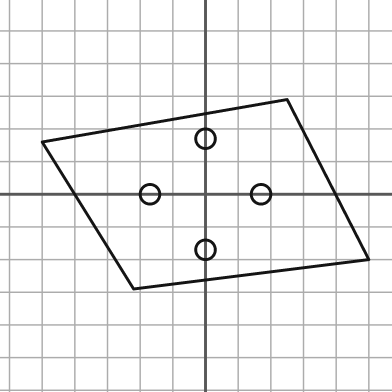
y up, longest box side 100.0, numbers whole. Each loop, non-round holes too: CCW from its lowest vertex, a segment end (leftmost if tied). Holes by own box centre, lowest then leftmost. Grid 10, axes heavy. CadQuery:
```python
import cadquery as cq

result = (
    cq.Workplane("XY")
    .moveTo(-22.0, -29.0)
    .lineTo(50.0, -20.0)
    .lineTo(25.0, 29.0)
    .lineTo(-50.0, 16.0)
    .close()
    .moveTo(0.0, -17.0)
    .circle(3.0)
    .moveTo(-17.0, 0.0)
    .circle(3.0)
    .moveTo(17.0, 0.0)
    .circle(3.0)
    .moveTo(0.0, 17.0)
    .circle(3.0)
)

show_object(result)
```